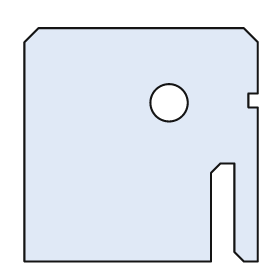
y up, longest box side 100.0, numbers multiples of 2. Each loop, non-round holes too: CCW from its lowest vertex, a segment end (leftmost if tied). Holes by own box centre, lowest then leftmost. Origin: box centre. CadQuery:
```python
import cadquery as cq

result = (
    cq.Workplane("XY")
    .moveTo(-50.0, -50.0)
    .lineTo(30.0, -50.0)
    .lineTo(30.0, -12.0)
    .lineTo(34.0, -8.0)
    .lineTo(40.0, -8.0)
    .lineTo(40.0, -46.0)
    .lineTo(44.0, -50.0)
    .lineTo(50.0, -50.0)
    .lineTo(50.0, 16.0)
    .lineTo(46.0, 16.0)
    .lineTo(46.0, 22.0)
    .lineTo(50.0, 22.0)
    .lineTo(50.0, 44.0)
    .lineTo(44.0, 50.0)
    .lineTo(-44.0, 50.0)
    .lineTo(-50.0, 44.0)
    .close()
    .moveTo(12.0, 18.0)
    .circle(8.0)
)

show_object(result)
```